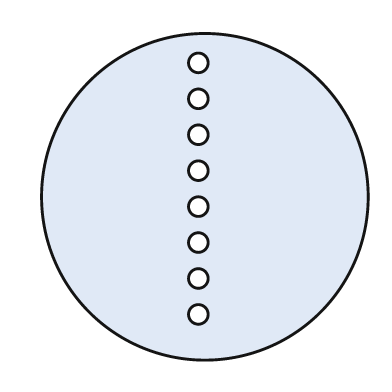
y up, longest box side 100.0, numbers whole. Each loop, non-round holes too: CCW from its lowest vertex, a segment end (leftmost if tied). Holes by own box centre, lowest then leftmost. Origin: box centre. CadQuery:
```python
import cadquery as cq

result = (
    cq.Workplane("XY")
    .moveTo(0.0, 0.0)
    .circle(50.0)
    .moveTo(-2.0, -36.0)
    .circle(3.0)
    .moveTo(-2.0, -25.0)
    .circle(3.0)
    .moveTo(-2.0, -14.0)
    .circle(3.0)
    .moveTo(-2.0, -3.0)
    .circle(3.0)
    .moveTo(-2.0, 8.0)
    .circle(3.0)
    .moveTo(-2.0, 19.0)
    .circle(3.0)
    .moveTo(-2.0, 30.0)
    .circle(3.0)
    .moveTo(-2.0, 41.0)
    .circle(3.0)
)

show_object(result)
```